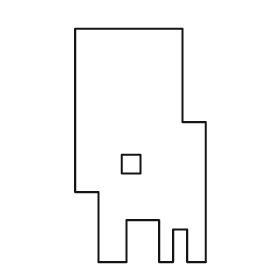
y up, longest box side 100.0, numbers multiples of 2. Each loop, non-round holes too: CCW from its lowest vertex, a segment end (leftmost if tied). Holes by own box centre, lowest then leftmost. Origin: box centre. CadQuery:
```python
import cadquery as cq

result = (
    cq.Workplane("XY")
    .moveTo(-18.0, -50.0)
    .lineTo(-6.0, -50.0)
    .lineTo(-6.0, -32.0)
    .lineTo(8.0, -32.0)
    .lineTo(8.0, -50.0)
    .lineTo(14.0, -50.0)
    .lineTo(14.0, -36.0)
    .lineTo(20.0, -36.0)
    .lineTo(20.0, -50.0)
    .lineTo(28.0, -50.0)
    .lineTo(28.0, 10.0)
    .lineTo(18.0, 10.0)
    .lineTo(18.0, 50.0)
    .lineTo(-28.0, 50.0)
    .lineTo(-28.0, -20.0)
    .lineTo(-18.0, -20.0)
    .close()
    .moveTo(-8.0, -12.0)
    .lineTo(0.0, -12.0)
    .lineTo(0.0, -4.0)
    .lineTo(-8.0, -4.0)
    .close()
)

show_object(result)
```